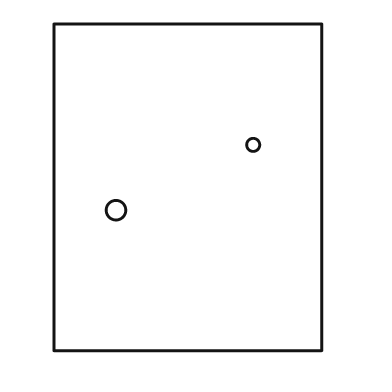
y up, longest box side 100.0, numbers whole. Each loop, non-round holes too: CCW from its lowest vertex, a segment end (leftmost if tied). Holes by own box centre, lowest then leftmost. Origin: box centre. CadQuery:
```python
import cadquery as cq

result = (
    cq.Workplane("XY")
    .moveTo(-41.0, -50.0)
    .lineTo(41.0, -50.0)
    .lineTo(41.0, 50.0)
    .lineTo(-41.0, 50.0)
    .close()
    .moveTo(-22.0, -7.0)
    .circle(3.0)
    .moveTo(20.0, 13.0)
    .circle(2.0)
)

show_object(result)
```